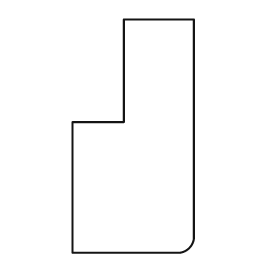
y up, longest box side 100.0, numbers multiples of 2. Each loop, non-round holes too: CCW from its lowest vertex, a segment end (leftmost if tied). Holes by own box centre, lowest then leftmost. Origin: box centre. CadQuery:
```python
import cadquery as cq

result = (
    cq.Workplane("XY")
    .moveTo(-26.0, -50.0)
    .lineTo(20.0, -50.0)
    .threePointArc((24.0, -48.0), (26.0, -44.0))
    .lineTo(26.0, 50.0)
    .lineTo(-4.0, 50.0)
    .lineTo(-4.0, 6.0)
    .lineTo(-26.0, 6.0)
    .close()
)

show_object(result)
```